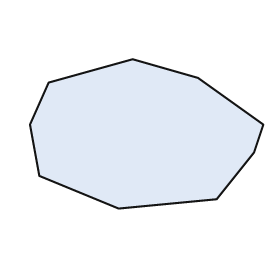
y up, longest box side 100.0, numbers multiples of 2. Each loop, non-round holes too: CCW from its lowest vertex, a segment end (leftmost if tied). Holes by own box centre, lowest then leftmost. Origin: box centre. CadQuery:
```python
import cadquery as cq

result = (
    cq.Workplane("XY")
    .moveTo(-12.0, -32.0)
    .lineTo(30.0, -28.0)
    .lineTo(46.0, -8.0)
    .lineTo(50.0, 4.0)
    .lineTo(22.0, 24.0)
    .lineTo(-6.0, 32.0)
    .lineTo(-42.0, 22.0)
    .lineTo(-50.0, 4.0)
    .lineTo(-46.0, -18.0)
    .close()
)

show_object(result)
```